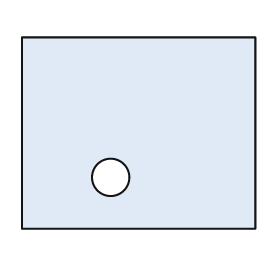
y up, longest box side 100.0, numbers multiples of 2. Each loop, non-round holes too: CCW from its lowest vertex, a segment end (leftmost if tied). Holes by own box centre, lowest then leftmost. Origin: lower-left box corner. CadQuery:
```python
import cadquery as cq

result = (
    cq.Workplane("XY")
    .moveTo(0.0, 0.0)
    .lineTo(100.0, 0.0)
    .lineTo(100.0, 82.0)
    .lineTo(0.0, 82.0)
    .close()
    .moveTo(38.0, 22.0)
    .circle(8.0)
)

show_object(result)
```